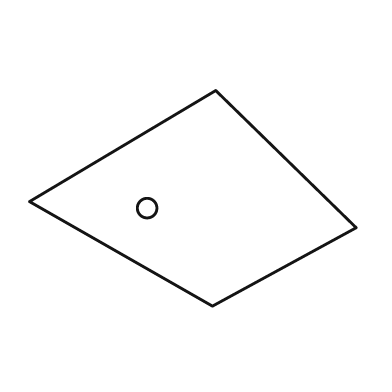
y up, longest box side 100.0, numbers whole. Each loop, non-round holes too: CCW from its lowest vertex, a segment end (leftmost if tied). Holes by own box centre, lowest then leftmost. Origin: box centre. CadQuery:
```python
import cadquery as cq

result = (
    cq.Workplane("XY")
    .moveTo(6.0, -33.0)
    .lineTo(50.0, -9.0)
    .lineTo(7.0, 33.0)
    .lineTo(-50.0, -1.0)
    .close()
    .moveTo(-14.0, -3.0)
    .circle(3.0)
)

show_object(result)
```